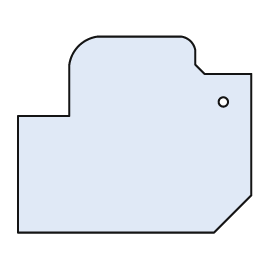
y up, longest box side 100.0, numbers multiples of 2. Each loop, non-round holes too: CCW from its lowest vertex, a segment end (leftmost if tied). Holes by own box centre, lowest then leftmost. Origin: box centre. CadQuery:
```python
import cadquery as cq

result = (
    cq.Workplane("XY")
    .moveTo(-50.0, -42.0)
    .lineTo(34.0, -42.0)
    .lineTo(50.0, -26.0)
    .lineTo(50.0, 26.0)
    .lineTo(30.0, 26.0)
    .lineTo(26.0, 30.0)
    .lineTo(26.0, 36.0)
    .threePointArc((24.0, 40.0), (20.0, 42.0))
    .lineTo(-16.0, 42.0)
    .threePointArc((-24.0, 38.0), (-28.0, 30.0))
    .lineTo(-28.0, 8.0)
    .lineTo(-50.0, 8.0)
    .close()
    .moveTo(38.0, 14.0)
    .circle(2.0)
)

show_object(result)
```